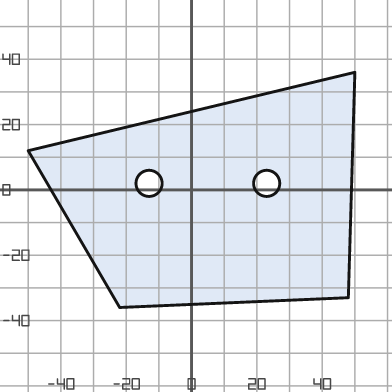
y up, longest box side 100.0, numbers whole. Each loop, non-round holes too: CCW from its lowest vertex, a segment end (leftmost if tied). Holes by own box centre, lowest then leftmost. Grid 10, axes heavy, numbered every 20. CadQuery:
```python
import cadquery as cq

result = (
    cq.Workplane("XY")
    .moveTo(-22.0, -36.0)
    .lineTo(48.0, -33.0)
    .lineTo(50.0, 36.0)
    .lineTo(-50.0, 12.0)
    .close()
    .moveTo(-13.0, 2.0)
    .circle(4.0)
    .moveTo(23.0, 2.0)
    .circle(4.0)
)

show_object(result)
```